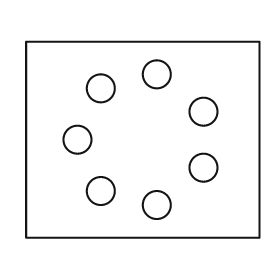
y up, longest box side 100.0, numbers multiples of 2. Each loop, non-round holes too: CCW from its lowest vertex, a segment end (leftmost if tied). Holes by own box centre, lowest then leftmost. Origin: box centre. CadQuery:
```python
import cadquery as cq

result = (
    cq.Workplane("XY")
    .moveTo(-50.0, -42.0)
    .lineTo(50.0, -42.0)
    .lineTo(50.0, 42.0)
    .lineTo(-50.0, 42.0)
    .close()
    .moveTo(6.0, -28.0)
    .circle(6.0)
    .moveTo(-18.0, -22.0)
    .circle(6.0)
    .moveTo(26.0, -12.0)
    .circle(6.0)
    .moveTo(-28.0, 0.0)
    .circle(6.0)
    .moveTo(26.0, 12.0)
    .circle(6.0)
    .moveTo(-18.0, 22.0)
    .circle(6.0)
    .moveTo(6.0, 28.0)
    .circle(6.0)
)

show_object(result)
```